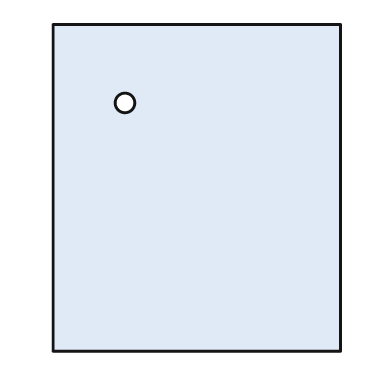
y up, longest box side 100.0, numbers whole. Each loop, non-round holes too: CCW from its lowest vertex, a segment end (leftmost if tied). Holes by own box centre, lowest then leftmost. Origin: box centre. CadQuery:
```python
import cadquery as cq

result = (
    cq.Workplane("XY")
    .moveTo(-44.0, -50.0)
    .lineTo(44.0, -50.0)
    .lineTo(44.0, 50.0)
    .lineTo(-44.0, 50.0)
    .close()
    .moveTo(-22.0, 26.0)
    .circle(3.0)
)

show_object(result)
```